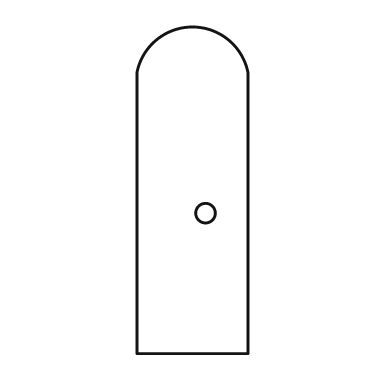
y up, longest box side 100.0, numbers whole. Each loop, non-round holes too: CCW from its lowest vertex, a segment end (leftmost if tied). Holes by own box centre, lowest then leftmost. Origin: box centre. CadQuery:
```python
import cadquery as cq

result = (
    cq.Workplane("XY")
    .moveTo(-17.0, -50.0)
    .lineTo(17.0, -50.0)
    .lineTo(17.0, 36.0)
    .threePointArc((0.0, 50.0), (-17.0, 36.0))
    .close()
    .moveTo(4.0, -7.0)
    .circle(3.0)
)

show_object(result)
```